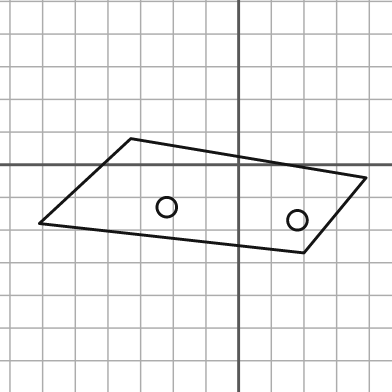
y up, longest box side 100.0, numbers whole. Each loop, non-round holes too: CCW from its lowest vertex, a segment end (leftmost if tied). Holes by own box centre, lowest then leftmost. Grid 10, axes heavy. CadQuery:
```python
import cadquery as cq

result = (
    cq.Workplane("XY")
    .moveTo(20.0, -27.0)
    .lineTo(39.0, -4.0)
    .lineTo(-33.0, 8.0)
    .lineTo(-61.0, -18.0)
    .close()
    .moveTo(18.0, -17.0)
    .circle(3.0)
    .moveTo(-22.0, -13.0)
    .circle(3.0)
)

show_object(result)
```